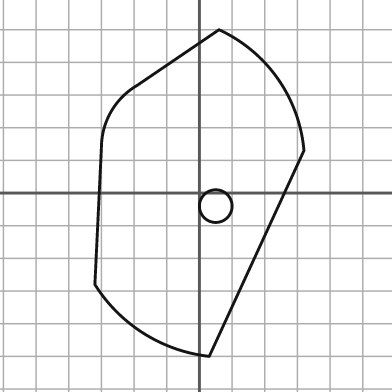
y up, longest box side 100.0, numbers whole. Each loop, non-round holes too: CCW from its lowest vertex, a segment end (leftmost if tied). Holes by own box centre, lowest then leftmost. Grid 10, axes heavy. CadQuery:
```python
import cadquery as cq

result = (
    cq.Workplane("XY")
    .moveTo(3.0, -50.0)
    .lineTo(32.0, 13.0)
    .threePointArc((24.0, 35.0), (6.0, 50.0))
    .lineTo(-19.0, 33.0)
    .threePointArc((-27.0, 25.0), (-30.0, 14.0))
    .lineTo(-32.0, -28.0)
    .threePointArc((-17.0, -43.0), (3.0, -50.0))
    .close()
    .moveTo(5.0, -4.0)
    .circle(5.0)
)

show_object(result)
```